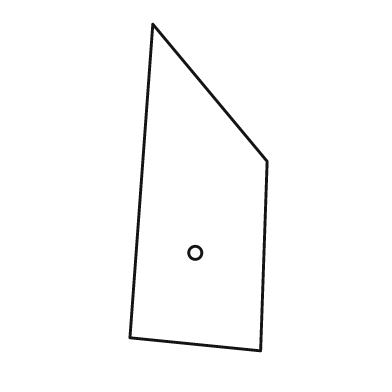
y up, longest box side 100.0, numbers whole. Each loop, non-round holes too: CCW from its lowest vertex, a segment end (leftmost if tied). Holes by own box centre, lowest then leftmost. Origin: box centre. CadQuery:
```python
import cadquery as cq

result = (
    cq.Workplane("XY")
    .moveTo(19.0, -50.0)
    .lineTo(21.0, 8.0)
    .lineTo(-14.0, 50.0)
    .lineTo(-21.0, -46.0)
    .close()
    .moveTo(-1.0, -20.0)
    .circle(2.0)
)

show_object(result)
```